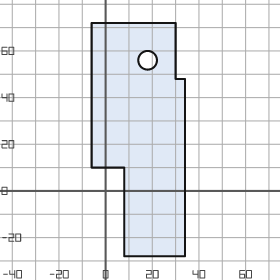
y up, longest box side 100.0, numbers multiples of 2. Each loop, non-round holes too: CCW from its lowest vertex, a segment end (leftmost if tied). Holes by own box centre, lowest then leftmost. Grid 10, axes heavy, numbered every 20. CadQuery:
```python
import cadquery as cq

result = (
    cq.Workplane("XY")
    .moveTo(8.0, -28.0)
    .lineTo(34.0, -28.0)
    .lineTo(34.0, 48.0)
    .lineTo(30.0, 48.0)
    .lineTo(30.0, 72.0)
    .lineTo(-6.0, 72.0)
    .lineTo(-6.0, 10.0)
    .lineTo(8.0, 10.0)
    .close()
    .moveTo(18.0, 56.0)
    .circle(4.0)
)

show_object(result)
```